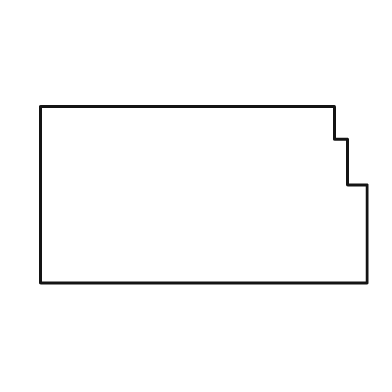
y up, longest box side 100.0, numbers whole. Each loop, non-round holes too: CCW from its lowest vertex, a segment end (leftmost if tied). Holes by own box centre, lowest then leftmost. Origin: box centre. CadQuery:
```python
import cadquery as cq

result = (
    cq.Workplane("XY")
    .moveTo(-50.0, -27.0)
    .lineTo(50.0, -27.0)
    .lineTo(50.0, 3.0)
    .lineTo(44.0, 3.0)
    .lineTo(44.0, 17.0)
    .lineTo(40.0, 17.0)
    .lineTo(40.0, 27.0)
    .lineTo(-50.0, 27.0)
    .close()
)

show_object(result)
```